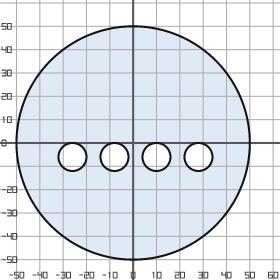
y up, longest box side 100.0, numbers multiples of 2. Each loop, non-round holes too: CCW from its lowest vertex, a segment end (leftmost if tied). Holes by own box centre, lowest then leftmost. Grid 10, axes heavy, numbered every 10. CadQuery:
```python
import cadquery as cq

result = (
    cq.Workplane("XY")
    .moveTo(0.0, 0.0)
    .circle(50.0)
    .moveTo(-26.0, -6.0)
    .circle(6.0)
    .moveTo(-8.0, -6.0)
    .circle(6.0)
    .moveTo(10.0, -6.0)
    .circle(6.0)
    .moveTo(28.0, -6.0)
    .circle(6.0)
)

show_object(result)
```